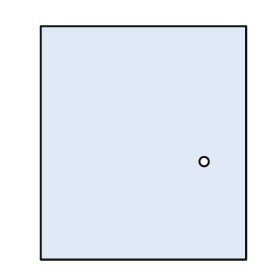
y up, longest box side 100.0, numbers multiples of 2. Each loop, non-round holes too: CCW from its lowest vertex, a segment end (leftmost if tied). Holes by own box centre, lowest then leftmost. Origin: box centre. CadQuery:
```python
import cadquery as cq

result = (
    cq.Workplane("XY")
    .moveTo(-44.0, -50.0)
    .lineTo(44.0, -50.0)
    .lineTo(44.0, 50.0)
    .lineTo(-44.0, 50.0)
    .close()
    .moveTo(26.0, -8.0)
    .circle(2.0)
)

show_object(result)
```